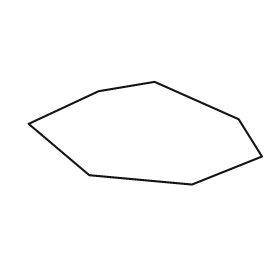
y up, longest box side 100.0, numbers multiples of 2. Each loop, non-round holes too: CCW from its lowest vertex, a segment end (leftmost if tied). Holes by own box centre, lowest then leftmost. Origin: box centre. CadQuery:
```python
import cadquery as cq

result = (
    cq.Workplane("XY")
    .moveTo(20.0, -22.0)
    .lineTo(50.0, -10.0)
    .lineTo(40.0, 6.0)
    .lineTo(4.0, 22.0)
    .lineTo(-20.0, 18.0)
    .lineTo(-50.0, 4.0)
    .lineTo(-24.0, -18.0)
    .close()
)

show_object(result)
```